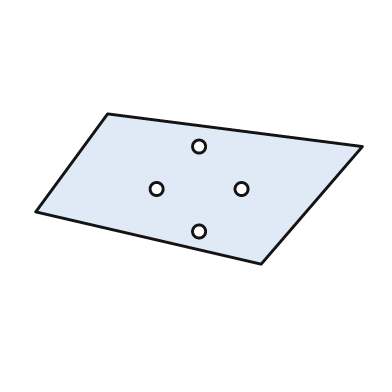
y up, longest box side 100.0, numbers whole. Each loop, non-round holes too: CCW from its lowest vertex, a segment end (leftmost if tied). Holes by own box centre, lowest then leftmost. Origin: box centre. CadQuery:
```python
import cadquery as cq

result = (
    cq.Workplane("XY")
    .moveTo(19.0, -23.0)
    .lineTo(50.0, 13.0)
    .lineTo(-28.0, 23.0)
    .lineTo(-50.0, -7.0)
    .close()
    .moveTo(0.0, -13.0)
    .circle(2.0)
    .moveTo(-13.0, 0.0)
    .circle(2.0)
    .moveTo(13.0, 0.0)
    .circle(2.0)
    .moveTo(0.0, 13.0)
    .circle(2.0)
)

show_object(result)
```